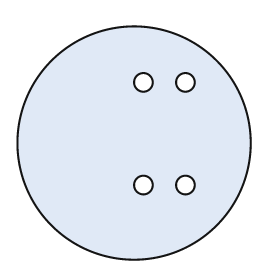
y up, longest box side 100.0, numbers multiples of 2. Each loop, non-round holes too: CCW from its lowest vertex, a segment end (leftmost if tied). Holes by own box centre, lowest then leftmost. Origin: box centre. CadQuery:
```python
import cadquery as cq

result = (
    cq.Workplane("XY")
    .moveTo(0.0, 0.0)
    .circle(50.0)
    .moveTo(4.0, -18.0)
    .circle(4.0)
    .moveTo(22.0, -18.0)
    .circle(4.0)
    .moveTo(4.0, 26.0)
    .circle(4.0)
    .moveTo(22.0, 26.0)
    .circle(4.0)
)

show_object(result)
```